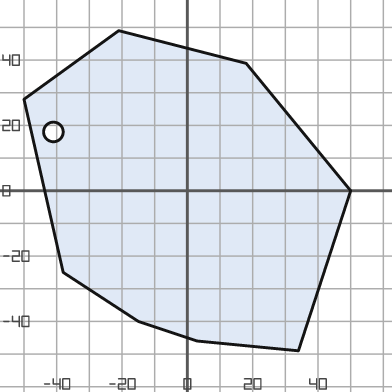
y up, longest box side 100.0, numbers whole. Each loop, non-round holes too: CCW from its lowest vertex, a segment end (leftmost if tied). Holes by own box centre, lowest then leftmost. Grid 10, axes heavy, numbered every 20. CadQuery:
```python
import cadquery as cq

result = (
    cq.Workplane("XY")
    .moveTo(34.0, -49.0)
    .lineTo(50.0, 0.0)
    .lineTo(18.0, 39.0)
    .lineTo(-21.0, 49.0)
    .lineTo(-50.0, 28.0)
    .lineTo(-38.0, -25.0)
    .lineTo(-15.0, -40.0)
    .lineTo(3.0, -46.0)
    .close()
    .moveTo(-41.0, 18.0)
    .circle(3.0)
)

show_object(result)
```